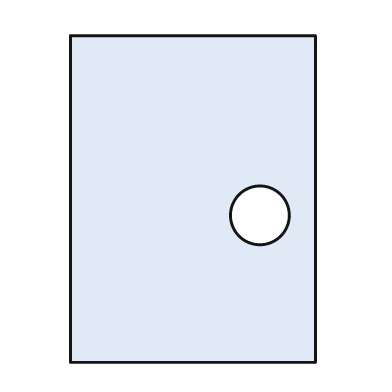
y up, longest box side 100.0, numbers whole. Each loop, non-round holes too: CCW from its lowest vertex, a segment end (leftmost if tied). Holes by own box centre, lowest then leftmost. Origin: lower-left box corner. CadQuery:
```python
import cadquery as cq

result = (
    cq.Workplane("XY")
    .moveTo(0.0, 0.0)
    .lineTo(75.0, 0.0)
    .lineTo(75.0, 100.0)
    .lineTo(0.0, 100.0)
    .close()
    .moveTo(58.0, 45.0)
    .circle(9.0)
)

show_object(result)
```